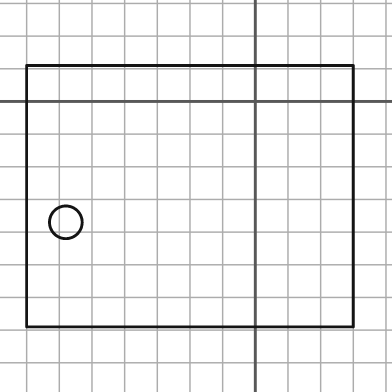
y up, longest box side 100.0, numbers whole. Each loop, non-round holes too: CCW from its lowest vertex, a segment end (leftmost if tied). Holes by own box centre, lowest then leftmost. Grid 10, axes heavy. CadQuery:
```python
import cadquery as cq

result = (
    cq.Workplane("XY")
    .moveTo(-70.0, -69.0)
    .lineTo(30.0, -69.0)
    .lineTo(30.0, 11.0)
    .lineTo(-70.0, 11.0)
    .close()
    .moveTo(-58.0, -37.0)
    .circle(5.0)
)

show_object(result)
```